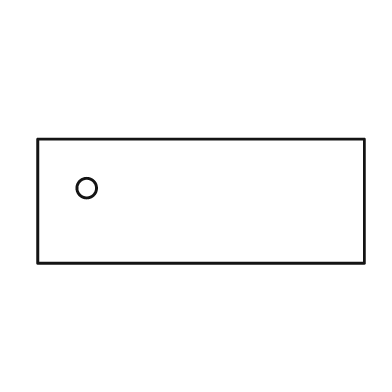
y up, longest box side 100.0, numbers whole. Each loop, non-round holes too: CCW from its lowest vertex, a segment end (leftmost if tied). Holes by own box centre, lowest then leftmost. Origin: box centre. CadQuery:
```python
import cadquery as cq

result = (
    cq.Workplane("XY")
    .moveTo(-50.0, -19.0)
    .lineTo(50.0, -19.0)
    .lineTo(50.0, 19.0)
    .lineTo(-50.0, 19.0)
    .close()
    .moveTo(-35.0, 4.0)
    .circle(3.0)
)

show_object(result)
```